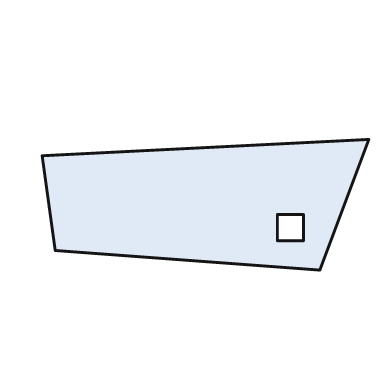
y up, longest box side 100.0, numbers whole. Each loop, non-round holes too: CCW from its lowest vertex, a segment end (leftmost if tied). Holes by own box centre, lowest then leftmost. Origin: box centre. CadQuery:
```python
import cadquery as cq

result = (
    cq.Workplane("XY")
    .moveTo(35.0, -20.0)
    .lineTo(50.0, 20.0)
    .lineTo(-50.0, 15.0)
    .lineTo(-46.0, -14.0)
    .close()
    .moveTo(22.0, -11.0)
    .lineTo(30.0, -11.0)
    .lineTo(30.0, -3.0)
    .lineTo(22.0, -3.0)
    .close()
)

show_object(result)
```